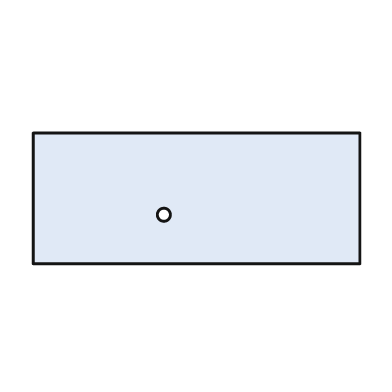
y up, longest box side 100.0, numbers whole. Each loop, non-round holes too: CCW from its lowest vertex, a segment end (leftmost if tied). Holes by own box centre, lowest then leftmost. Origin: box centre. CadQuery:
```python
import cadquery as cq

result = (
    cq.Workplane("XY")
    .moveTo(-50.0, -20.0)
    .lineTo(50.0, -20.0)
    .lineTo(50.0, 20.0)
    .lineTo(-50.0, 20.0)
    .close()
    .moveTo(-10.0, -5.0)
    .circle(2.0)
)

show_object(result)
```